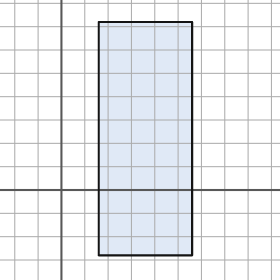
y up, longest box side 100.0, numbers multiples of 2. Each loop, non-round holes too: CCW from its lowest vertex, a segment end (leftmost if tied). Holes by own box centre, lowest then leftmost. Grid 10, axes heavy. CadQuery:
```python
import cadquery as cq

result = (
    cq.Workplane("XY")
    .moveTo(16.0, -28.0)
    .lineTo(56.0, -28.0)
    .lineTo(56.0, 72.0)
    .lineTo(16.0, 72.0)
    .close()
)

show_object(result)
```